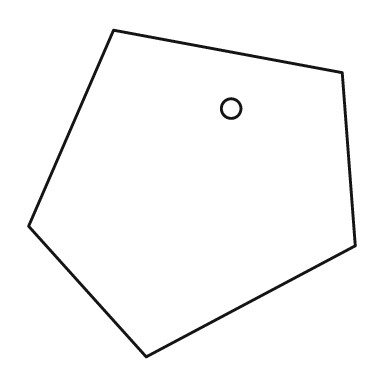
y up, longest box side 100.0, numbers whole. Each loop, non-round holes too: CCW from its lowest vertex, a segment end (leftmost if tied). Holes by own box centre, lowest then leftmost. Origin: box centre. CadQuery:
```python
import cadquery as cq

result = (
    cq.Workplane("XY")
    .moveTo(-14.0, -50.0)
    .lineTo(50.0, -16.0)
    .lineTo(46.0, 37.0)
    .lineTo(-24.0, 50.0)
    .lineTo(-50.0, -10.0)
    .close()
    .moveTo(12.0, 26.0)
    .circle(3.0)
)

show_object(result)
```